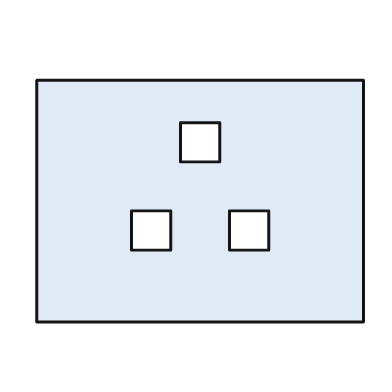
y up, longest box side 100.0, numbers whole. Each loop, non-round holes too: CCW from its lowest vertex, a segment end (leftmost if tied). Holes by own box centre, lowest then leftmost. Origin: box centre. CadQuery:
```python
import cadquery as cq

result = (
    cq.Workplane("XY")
    .moveTo(-50.0, -37.0)
    .lineTo(50.0, -37.0)
    .lineTo(50.0, 37.0)
    .lineTo(-50.0, 37.0)
    .close()
    .moveTo(-21.0, -15.0)
    .lineTo(-9.0, -15.0)
    .lineTo(-9.0, -3.0)
    .lineTo(-21.0, -3.0)
    .close()
    .moveTo(9.0, -15.0)
    .lineTo(21.0, -15.0)
    .lineTo(21.0, -3.0)
    .lineTo(9.0, -3.0)
    .close()
    .moveTo(-6.0, 12.0)
    .lineTo(6.0, 12.0)
    .lineTo(6.0, 24.0)
    .lineTo(-6.0, 24.0)
    .close()
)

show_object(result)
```